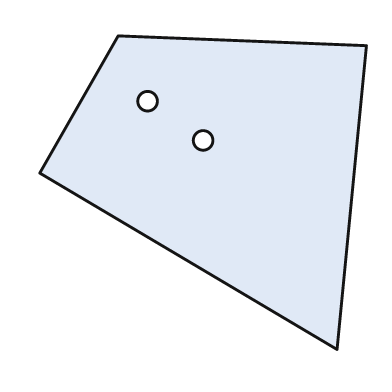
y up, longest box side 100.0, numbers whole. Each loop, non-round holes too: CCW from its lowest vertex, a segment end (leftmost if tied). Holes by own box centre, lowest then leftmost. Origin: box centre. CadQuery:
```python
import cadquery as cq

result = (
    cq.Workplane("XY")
    .moveTo(41.0, -48.0)
    .lineTo(50.0, 45.0)
    .lineTo(-26.0, 48.0)
    .lineTo(-50.0, 6.0)
    .close()
    .moveTo(0.0, 16.0)
    .circle(3.0)
    .moveTo(-17.0, 28.0)
    .circle(3.0)
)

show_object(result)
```